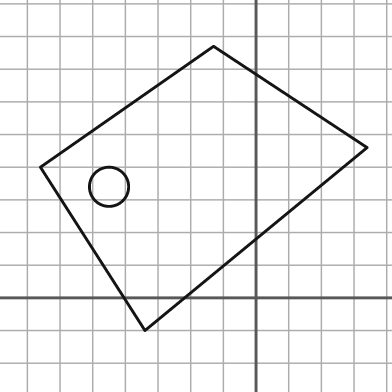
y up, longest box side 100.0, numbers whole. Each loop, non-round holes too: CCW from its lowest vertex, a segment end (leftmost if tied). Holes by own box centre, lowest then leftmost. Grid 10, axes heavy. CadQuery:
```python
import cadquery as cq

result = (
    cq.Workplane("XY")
    .moveTo(-34.0, -10.0)
    .lineTo(34.0, 46.0)
    .lineTo(-13.0, 77.0)
    .lineTo(-66.0, 40.0)
    .close()
    .moveTo(-45.0, 34.0)
    .circle(6.0)
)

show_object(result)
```